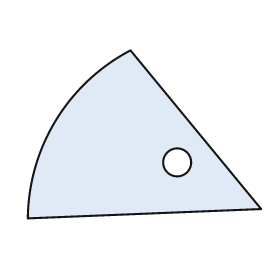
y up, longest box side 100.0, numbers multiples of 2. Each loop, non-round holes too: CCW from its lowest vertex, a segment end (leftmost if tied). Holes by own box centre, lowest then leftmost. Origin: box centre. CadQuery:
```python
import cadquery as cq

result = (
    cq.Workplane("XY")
    .moveTo(-50.0, -36.0)
    .lineTo(50.0, -32.0)
    .lineTo(-6.0, 36.0)
    .threePointArc((-38.0, 6.0), (-50.0, -36.0))
    .close()
    .moveTo(14.0, -12.0)
    .circle(6.0)
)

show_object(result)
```